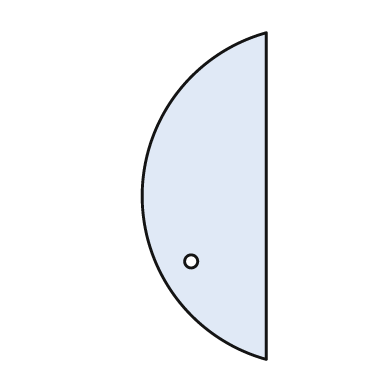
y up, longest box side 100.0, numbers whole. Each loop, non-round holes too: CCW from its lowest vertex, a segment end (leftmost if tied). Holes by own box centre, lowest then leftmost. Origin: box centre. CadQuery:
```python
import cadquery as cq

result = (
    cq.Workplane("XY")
    .moveTo(19.0, -50.0)
    .lineTo(19.0, 50.0)
    .threePointArc((-19.0, 0.0), (19.0, -50.0))
    .close()
    .moveTo(-4.0, -20.0)
    .circle(2.0)
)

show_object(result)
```